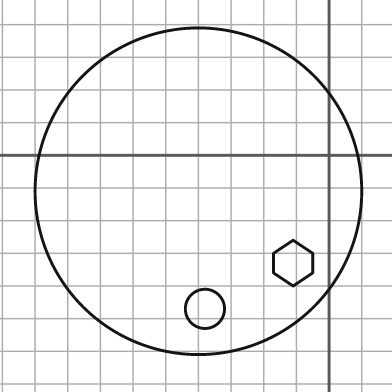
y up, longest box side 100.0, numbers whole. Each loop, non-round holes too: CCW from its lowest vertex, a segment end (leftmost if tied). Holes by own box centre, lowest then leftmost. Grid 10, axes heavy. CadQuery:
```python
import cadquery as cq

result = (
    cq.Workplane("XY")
    .moveTo(-40.0, -11.0)
    .circle(50.0)
    .moveTo(-38.0, -47.0)
    .circle(6.0)
    .moveTo(-11.0, -40.0)
    .lineTo(-5.0, -36.0)
    .lineTo(-5.0, -30.0)
    .lineTo(-11.0, -26.0)
    .lineTo(-17.0, -30.0)
    .lineTo(-17.0, -36.0)
    .close()
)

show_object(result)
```